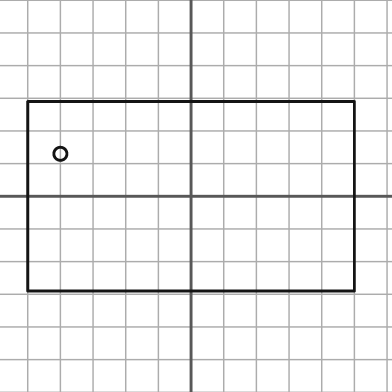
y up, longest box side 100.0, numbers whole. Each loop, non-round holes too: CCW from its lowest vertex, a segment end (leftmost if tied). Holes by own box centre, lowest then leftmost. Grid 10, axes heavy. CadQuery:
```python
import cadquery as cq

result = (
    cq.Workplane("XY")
    .moveTo(-50.0, -29.0)
    .lineTo(50.0, -29.0)
    .lineTo(50.0, 29.0)
    .lineTo(-50.0, 29.0)
    .close()
    .moveTo(-40.0, 13.0)
    .circle(2.0)
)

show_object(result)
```